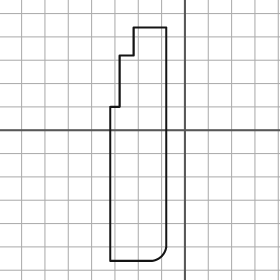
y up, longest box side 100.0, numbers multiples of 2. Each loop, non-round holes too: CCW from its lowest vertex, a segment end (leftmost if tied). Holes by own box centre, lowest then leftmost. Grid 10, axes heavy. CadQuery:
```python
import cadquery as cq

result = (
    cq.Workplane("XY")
    .moveTo(-32.0, -56.0)
    .lineTo(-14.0, -56.0)
    .threePointArc((-10.0, -54.0), (-8.0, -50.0))
    .lineTo(-8.0, 44.0)
    .lineTo(-22.0, 44.0)
    .lineTo(-22.0, 32.0)
    .lineTo(-28.0, 32.0)
    .lineTo(-28.0, 10.0)
    .lineTo(-32.0, 10.0)
    .close()
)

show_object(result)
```